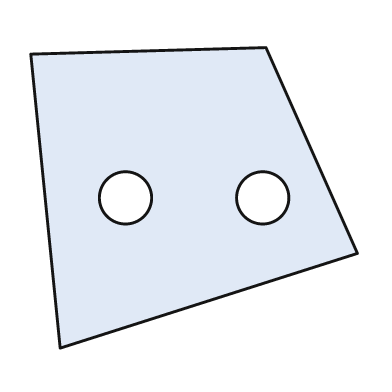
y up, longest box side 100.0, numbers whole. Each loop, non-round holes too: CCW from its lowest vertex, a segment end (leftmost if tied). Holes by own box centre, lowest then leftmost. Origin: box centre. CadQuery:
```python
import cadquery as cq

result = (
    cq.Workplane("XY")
    .moveTo(-41.0, -46.0)
    .lineTo(50.0, -17.0)
    .lineTo(22.0, 46.0)
    .lineTo(-50.0, 44.0)
    .close()
    .moveTo(-21.0, 0.0)
    .circle(8.0)
    .moveTo(21.0, 0.0)
    .circle(8.0)
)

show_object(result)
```